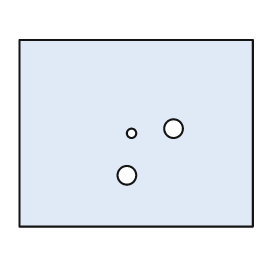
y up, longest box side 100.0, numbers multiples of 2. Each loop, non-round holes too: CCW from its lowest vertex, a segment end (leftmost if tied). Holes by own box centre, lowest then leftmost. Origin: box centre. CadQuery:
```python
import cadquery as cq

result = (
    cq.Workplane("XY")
    .moveTo(-50.0, -40.0)
    .lineTo(50.0, -40.0)
    .lineTo(50.0, 40.0)
    .lineTo(-50.0, 40.0)
    .close()
    .moveTo(-4.0, -18.0)
    .circle(4.0)
    .moveTo(-2.0, 0.0)
    .circle(2.0)
    .moveTo(16.0, 2.0)
    .circle(4.0)
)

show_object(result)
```